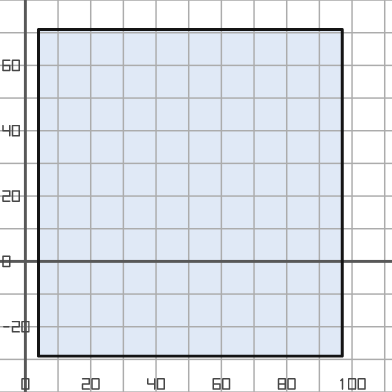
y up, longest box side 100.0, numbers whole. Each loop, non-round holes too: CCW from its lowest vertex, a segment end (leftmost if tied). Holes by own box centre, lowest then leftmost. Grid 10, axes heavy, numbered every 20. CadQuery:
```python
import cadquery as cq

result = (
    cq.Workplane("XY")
    .moveTo(4.0, -29.0)
    .lineTo(97.0, -29.0)
    .lineTo(97.0, 71.0)
    .lineTo(4.0, 71.0)
    .close()
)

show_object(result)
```